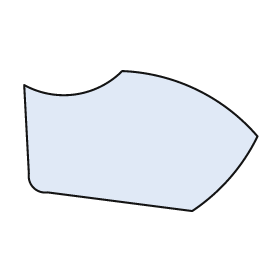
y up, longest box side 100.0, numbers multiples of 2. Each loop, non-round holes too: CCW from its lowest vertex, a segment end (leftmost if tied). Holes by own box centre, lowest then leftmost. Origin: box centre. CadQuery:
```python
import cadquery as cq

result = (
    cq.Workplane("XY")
    .moveTo(22.0, -30.0)
    .threePointArc((38.0, -16.0), (50.0, 2.0))
    .threePointArc((24.0, 22.0), (-8.0, 30.0))
    .threePointArc((-28.0, 20.0), (-50.0, 24.0))
    .lineTo(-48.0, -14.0)
    .threePointArc((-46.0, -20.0), (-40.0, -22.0))
    .close()
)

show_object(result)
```